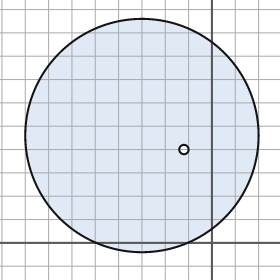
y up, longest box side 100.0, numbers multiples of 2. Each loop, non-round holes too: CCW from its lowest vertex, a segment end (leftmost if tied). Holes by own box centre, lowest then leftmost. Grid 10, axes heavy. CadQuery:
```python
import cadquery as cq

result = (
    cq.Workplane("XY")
    .moveTo(-30.0, 46.0)
    .circle(50.0)
    .moveTo(-12.0, 40.0)
    .circle(2.0)
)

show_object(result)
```